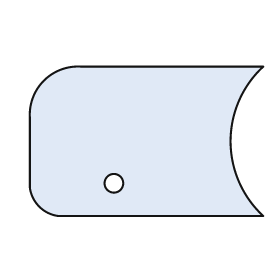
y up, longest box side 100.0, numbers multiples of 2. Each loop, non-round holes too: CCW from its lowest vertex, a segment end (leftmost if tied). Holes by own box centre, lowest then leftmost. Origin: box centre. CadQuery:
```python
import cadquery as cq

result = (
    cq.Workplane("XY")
    .moveTo(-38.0, -32.0)
    .lineTo(50.0, -32.0)
    .threePointArc((36.0, 0.0), (50.0, 32.0))
    .lineTo(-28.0, 32.0)
    .threePointArc((-44.0, 26.0), (-50.0, 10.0))
    .lineTo(-50.0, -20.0)
    .threePointArc((-46.0, -28.0), (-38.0, -32.0))
    .close()
    .moveTo(-14.0, -18.0)
    .circle(4.0)
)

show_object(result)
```